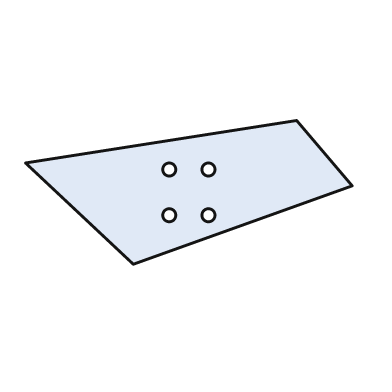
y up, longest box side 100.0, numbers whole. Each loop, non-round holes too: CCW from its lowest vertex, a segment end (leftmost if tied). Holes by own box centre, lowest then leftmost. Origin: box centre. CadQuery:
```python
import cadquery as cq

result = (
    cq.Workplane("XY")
    .moveTo(-17.0, -22.0)
    .lineTo(50.0, 2.0)
    .lineTo(33.0, 22.0)
    .lineTo(-50.0, 9.0)
    .close()
    .moveTo(-6.0, -7.0)
    .circle(2.0)
    .moveTo(6.0, -7.0)
    .circle(2.0)
    .moveTo(-6.0, 7.0)
    .circle(2.0)
    .moveTo(6.0, 7.0)
    .circle(2.0)
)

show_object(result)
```